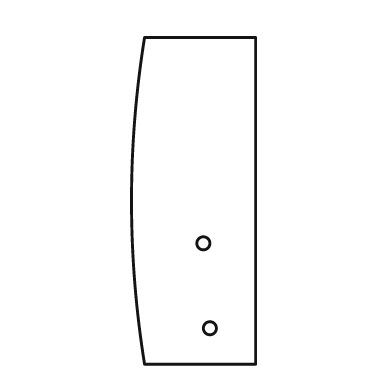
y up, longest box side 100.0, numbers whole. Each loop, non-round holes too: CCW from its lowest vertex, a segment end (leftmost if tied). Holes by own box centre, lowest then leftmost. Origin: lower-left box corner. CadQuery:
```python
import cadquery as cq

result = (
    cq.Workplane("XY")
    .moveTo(4.0, 0.0)
    .lineTo(38.0, 0.0)
    .lineTo(38.0, 100.0)
    .lineTo(4.0, 100.0)
    .threePointArc((0.0, 50.0), (4.0, 0.0))
    .close()
    .moveTo(24.0, 11.0)
    .circle(2.0)
    .moveTo(22.0, 37.0)
    .circle(2.0)
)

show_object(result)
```